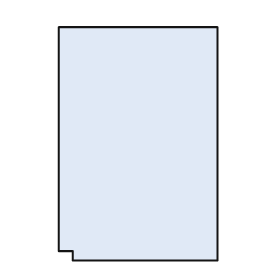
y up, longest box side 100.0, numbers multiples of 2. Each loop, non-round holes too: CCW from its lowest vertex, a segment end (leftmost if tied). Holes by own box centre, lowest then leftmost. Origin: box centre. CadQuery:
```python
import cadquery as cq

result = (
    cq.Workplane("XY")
    .moveTo(-28.0, -50.0)
    .lineTo(34.0, -50.0)
    .lineTo(34.0, 50.0)
    .lineTo(-34.0, 50.0)
    .lineTo(-34.0, -46.0)
    .lineTo(-28.0, -46.0)
    .close()
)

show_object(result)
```